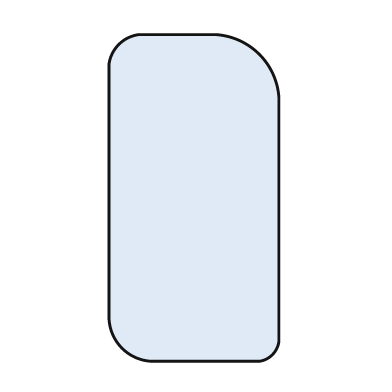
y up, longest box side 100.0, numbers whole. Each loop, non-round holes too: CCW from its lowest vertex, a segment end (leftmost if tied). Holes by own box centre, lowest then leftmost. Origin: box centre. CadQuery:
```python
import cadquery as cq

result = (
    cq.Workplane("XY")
    .moveTo(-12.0, -50.0)
    .lineTo(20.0, -50.0)
    .threePointArc((24.0, -48.0), (26.0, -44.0))
    .lineTo(26.0, 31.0)
    .threePointArc((20.0, 44.0), (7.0, 50.0))
    .lineTo(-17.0, 50.0)
    .threePointArc((-23.0, 47.0), (-26.0, 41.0))
    .lineTo(-26.0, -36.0)
    .threePointArc((-22.0, -46.0), (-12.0, -50.0))
    .close()
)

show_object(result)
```